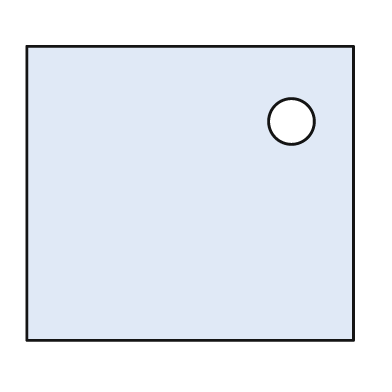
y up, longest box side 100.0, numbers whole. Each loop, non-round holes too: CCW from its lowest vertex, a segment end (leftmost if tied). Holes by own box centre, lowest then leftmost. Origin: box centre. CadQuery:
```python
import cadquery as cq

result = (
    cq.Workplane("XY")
    .moveTo(-50.0, -45.0)
    .lineTo(50.0, -45.0)
    .lineTo(50.0, 45.0)
    .lineTo(-50.0, 45.0)
    .close()
    .moveTo(31.0, 22.0)
    .circle(7.0)
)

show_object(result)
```